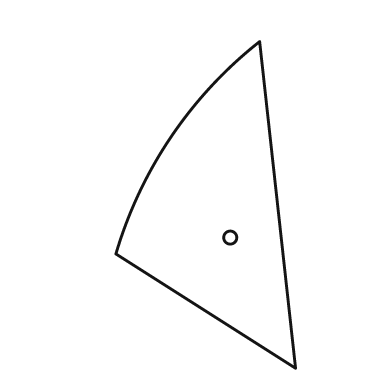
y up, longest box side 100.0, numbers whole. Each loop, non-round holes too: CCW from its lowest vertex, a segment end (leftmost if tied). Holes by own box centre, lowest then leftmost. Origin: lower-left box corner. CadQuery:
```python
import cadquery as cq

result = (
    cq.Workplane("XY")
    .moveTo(55.0, 0.0)
    .lineTo(44.0, 100.0)
    .threePointArc((17.0, 71.0), (0.0, 35.0))
    .close()
    .moveTo(35.0, 40.0)
    .circle(2.0)
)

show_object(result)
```